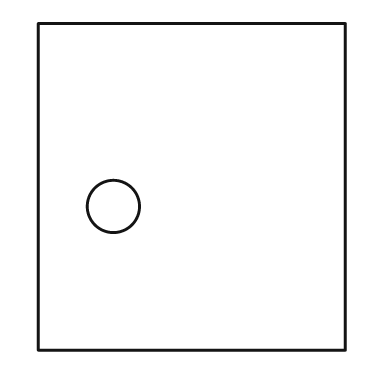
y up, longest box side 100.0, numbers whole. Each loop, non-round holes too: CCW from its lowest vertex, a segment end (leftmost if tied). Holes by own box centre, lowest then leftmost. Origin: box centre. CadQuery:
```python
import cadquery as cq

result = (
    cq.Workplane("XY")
    .moveTo(-47.0, -50.0)
    .lineTo(47.0, -50.0)
    .lineTo(47.0, 50.0)
    .lineTo(-47.0, 50.0)
    .close()
    .moveTo(-24.0, -6.0)
    .circle(8.0)
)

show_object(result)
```